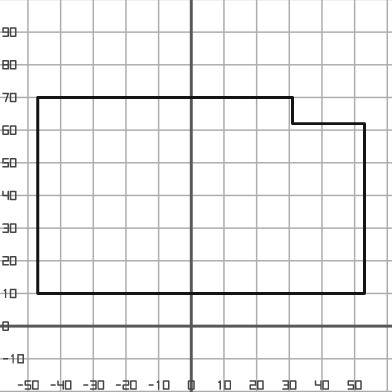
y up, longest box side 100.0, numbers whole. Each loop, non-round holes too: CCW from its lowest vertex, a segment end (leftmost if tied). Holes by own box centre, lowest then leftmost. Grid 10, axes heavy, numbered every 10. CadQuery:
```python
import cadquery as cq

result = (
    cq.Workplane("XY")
    .moveTo(-47.0, 10.0)
    .lineTo(53.0, 10.0)
    .lineTo(53.0, 62.0)
    .lineTo(31.0, 62.0)
    .lineTo(31.0, 70.0)
    .lineTo(-47.0, 70.0)
    .close()
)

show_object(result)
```